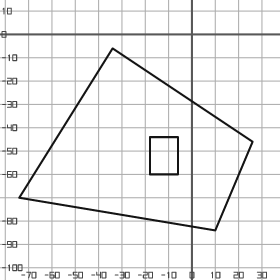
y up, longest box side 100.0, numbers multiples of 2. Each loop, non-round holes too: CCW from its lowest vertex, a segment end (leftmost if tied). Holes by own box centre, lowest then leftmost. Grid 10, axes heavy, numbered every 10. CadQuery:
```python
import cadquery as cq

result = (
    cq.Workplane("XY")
    .moveTo(10.0, -84.0)
    .lineTo(26.0, -46.0)
    .lineTo(-34.0, -6.0)
    .lineTo(-74.0, -70.0)
    .close()
    .moveTo(-18.0, -60.0)
    .lineTo(-6.0, -60.0)
    .lineTo(-6.0, -44.0)
    .lineTo(-18.0, -44.0)
    .close()
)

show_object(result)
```